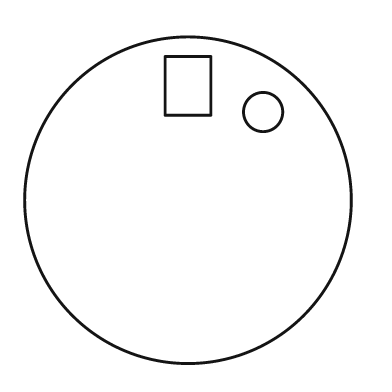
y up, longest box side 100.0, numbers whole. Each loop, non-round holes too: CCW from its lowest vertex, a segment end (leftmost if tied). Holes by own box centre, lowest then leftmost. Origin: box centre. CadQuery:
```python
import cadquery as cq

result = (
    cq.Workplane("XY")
    .moveTo(0.0, 0.0)
    .circle(50.0)
    .moveTo(23.0, 27.0)
    .circle(6.0)
    .moveTo(-7.0, 26.0)
    .lineTo(7.0, 26.0)
    .lineTo(7.0, 44.0)
    .lineTo(-7.0, 44.0)
    .close()
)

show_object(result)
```